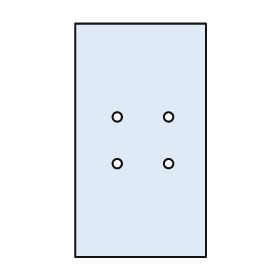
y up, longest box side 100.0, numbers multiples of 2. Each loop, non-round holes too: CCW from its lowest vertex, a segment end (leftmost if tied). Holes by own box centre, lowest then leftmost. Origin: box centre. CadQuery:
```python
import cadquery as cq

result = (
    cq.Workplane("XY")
    .moveTo(-28.0, -50.0)
    .lineTo(28.0, -50.0)
    .lineTo(28.0, 50.0)
    .lineTo(-28.0, 50.0)
    .close()
    .moveTo(-10.0, -10.0)
    .circle(2.0)
    .moveTo(12.0, -10.0)
    .circle(2.0)
    .moveTo(-10.0, 10.0)
    .circle(2.0)
    .moveTo(12.0, 10.0)
    .circle(2.0)
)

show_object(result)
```